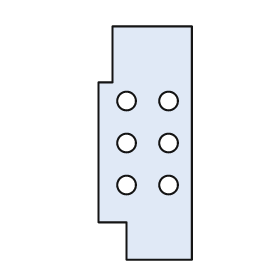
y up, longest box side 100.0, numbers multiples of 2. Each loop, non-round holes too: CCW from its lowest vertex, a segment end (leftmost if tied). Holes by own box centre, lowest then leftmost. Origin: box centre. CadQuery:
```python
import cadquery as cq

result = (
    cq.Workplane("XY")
    .moveTo(-8.0, -50.0)
    .lineTo(20.0, -50.0)
    .lineTo(20.0, 50.0)
    .lineTo(-14.0, 50.0)
    .lineTo(-14.0, 26.0)
    .lineTo(-20.0, 26.0)
    .lineTo(-20.0, -34.0)
    .lineTo(-8.0, -34.0)
    .close()
    .moveTo(-8.0, -18.0)
    .circle(4.0)
    .moveTo(10.0, -18.0)
    .circle(4.0)
    .moveTo(-8.0, 0.0)
    .circle(4.0)
    .moveTo(10.0, 0.0)
    .circle(4.0)
    .moveTo(-8.0, 18.0)
    .circle(4.0)
    .moveTo(10.0, 18.0)
    .circle(4.0)
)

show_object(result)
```